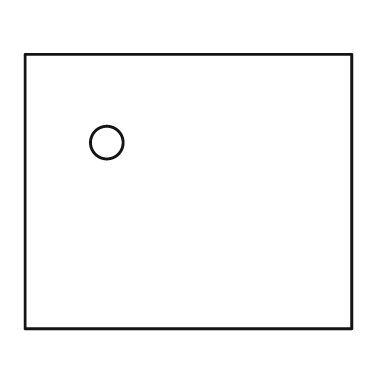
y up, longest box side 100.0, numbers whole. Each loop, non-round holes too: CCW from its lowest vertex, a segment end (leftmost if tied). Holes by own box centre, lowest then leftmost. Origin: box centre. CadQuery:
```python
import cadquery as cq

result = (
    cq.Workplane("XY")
    .moveTo(-50.0, -42.0)
    .lineTo(50.0, -42.0)
    .lineTo(50.0, 42.0)
    .lineTo(-50.0, 42.0)
    .close()
    .moveTo(-25.0, 15.0)
    .circle(5.0)
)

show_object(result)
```